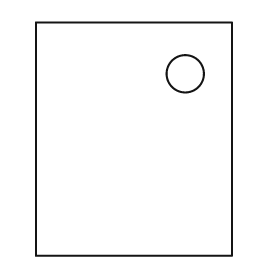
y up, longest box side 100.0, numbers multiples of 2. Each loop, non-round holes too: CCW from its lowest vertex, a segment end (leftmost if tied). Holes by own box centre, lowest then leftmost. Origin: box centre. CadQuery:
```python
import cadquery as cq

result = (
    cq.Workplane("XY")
    .moveTo(-42.0, -50.0)
    .lineTo(42.0, -50.0)
    .lineTo(42.0, 50.0)
    .lineTo(-42.0, 50.0)
    .close()
    .moveTo(22.0, 28.0)
    .circle(8.0)
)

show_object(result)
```